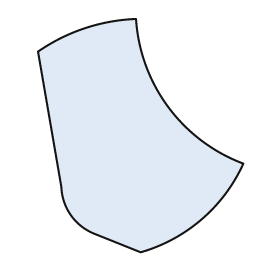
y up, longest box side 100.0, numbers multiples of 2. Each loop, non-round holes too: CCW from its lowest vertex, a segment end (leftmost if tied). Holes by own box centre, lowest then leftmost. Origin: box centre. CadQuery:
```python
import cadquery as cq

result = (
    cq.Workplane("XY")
    .moveTo(0.0, -50.0)
    .threePointArc((26.0, -36.0), (44.0, -12.0))
    .threePointArc((12.0, 12.0), (-2.0, 50.0))
    .threePointArc((-24.0, 46.0), (-44.0, 36.0))
    .lineTo(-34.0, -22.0)
    .threePointArc((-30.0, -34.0), (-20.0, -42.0))
    .close()
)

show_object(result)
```